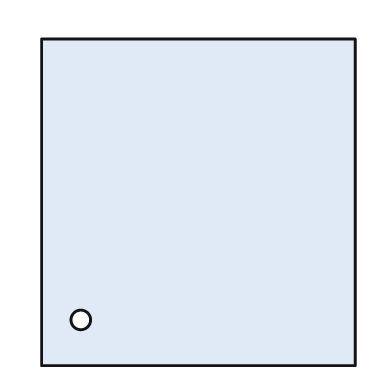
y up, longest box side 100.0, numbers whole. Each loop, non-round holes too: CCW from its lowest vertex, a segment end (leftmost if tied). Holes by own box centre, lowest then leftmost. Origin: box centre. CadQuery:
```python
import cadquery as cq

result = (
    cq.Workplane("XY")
    .moveTo(-48.0, -50.0)
    .lineTo(48.0, -50.0)
    .lineTo(48.0, 50.0)
    .lineTo(-48.0, 50.0)
    .close()
    .moveTo(-36.0, -36.0)
    .circle(3.0)
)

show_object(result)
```